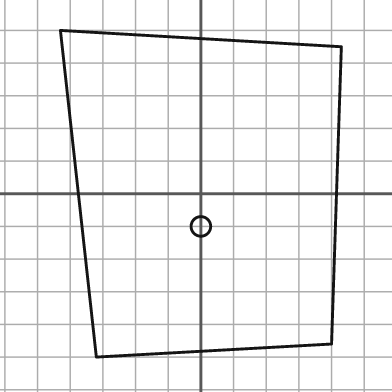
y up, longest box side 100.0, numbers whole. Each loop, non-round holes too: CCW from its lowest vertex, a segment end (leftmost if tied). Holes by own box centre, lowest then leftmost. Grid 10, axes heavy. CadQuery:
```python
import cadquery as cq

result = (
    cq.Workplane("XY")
    .moveTo(-32.0, -50.0)
    .lineTo(40.0, -46.0)
    .lineTo(43.0, 45.0)
    .lineTo(-43.0, 50.0)
    .close()
    .moveTo(0.0, -10.0)
    .circle(3.0)
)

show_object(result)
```